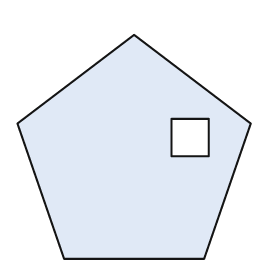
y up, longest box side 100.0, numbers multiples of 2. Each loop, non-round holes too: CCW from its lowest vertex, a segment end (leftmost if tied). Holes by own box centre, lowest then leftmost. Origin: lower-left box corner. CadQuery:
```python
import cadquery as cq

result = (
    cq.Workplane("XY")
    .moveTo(20.0, 0.0)
    .lineTo(80.0, 0.0)
    .lineTo(100.0, 58.0)
    .lineTo(50.0, 96.0)
    .lineTo(0.0, 58.0)
    .close()
    .moveTo(66.0, 44.0)
    .lineTo(82.0, 44.0)
    .lineTo(82.0, 60.0)
    .lineTo(66.0, 60.0)
    .close()
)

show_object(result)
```